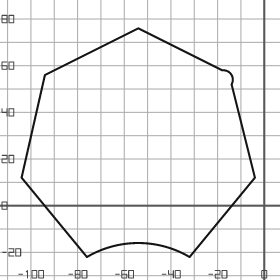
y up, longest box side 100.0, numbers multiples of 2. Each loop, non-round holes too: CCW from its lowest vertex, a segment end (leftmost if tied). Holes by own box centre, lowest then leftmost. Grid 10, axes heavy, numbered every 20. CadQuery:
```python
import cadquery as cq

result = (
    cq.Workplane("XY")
    .moveTo(-76.0, -22.0)
    .threePointArc((-54.0, -16.0), (-32.0, -22.0))
    .lineTo(-4.0, 12.0)
    .lineTo(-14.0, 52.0)
    .threePointArc((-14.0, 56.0), (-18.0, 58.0))
    .lineTo(-54.0, 76.0)
    .lineTo(-94.0, 56.0)
    .lineTo(-104.0, 12.0)
    .close()
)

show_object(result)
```